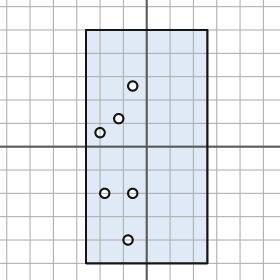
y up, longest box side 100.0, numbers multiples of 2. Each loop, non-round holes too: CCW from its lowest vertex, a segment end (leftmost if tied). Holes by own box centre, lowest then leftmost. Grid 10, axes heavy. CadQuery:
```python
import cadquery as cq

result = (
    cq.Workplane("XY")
    .moveTo(-26.0, -50.0)
    .lineTo(26.0, -50.0)
    .lineTo(26.0, 50.0)
    .lineTo(-26.0, 50.0)
    .close()
    .moveTo(-8.0, -40.0)
    .circle(2.0)
    .moveTo(-18.0, -20.0)
    .circle(2.0)
    .moveTo(-6.0, -20.0)
    .circle(2.0)
    .moveTo(-20.0, 6.0)
    .circle(2.0)
    .moveTo(-12.0, 12.0)
    .circle(2.0)
    .moveTo(-6.0, 26.0)
    .circle(2.0)
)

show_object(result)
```